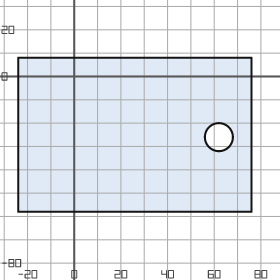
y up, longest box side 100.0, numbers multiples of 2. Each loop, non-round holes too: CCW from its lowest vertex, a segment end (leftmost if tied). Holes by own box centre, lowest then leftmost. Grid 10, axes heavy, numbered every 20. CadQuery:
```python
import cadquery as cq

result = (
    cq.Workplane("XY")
    .moveTo(-24.0, -58.0)
    .lineTo(76.0, -58.0)
    .lineTo(76.0, 8.0)
    .lineTo(-24.0, 8.0)
    .close()
    .moveTo(62.0, -26.0)
    .circle(6.0)
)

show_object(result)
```